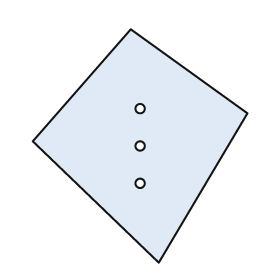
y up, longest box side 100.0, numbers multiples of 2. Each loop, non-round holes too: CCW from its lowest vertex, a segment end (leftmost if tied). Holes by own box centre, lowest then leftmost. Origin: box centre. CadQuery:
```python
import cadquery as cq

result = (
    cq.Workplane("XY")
    .moveTo(8.0, -50.0)
    .lineTo(46.0, 14.0)
    .lineTo(-4.0, 50.0)
    .lineTo(-46.0, 2.0)
    .close()
    .moveTo(0.0, -16.0)
    .circle(2.0)
    .moveTo(0.0, 0.0)
    .circle(2.0)
    .moveTo(0.0, 16.0)
    .circle(2.0)
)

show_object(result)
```